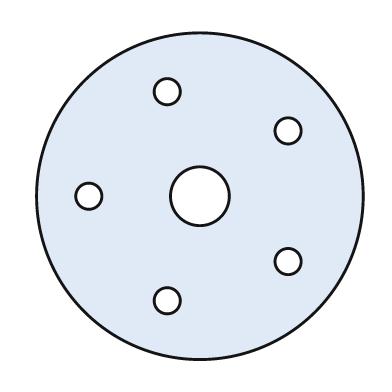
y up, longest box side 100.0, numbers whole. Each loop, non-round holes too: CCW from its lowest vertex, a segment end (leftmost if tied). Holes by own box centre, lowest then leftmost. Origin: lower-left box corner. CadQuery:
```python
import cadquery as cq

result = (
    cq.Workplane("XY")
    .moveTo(50.0, 50.0)
    .circle(50.0)
    .moveTo(40.0, 18.0)
    .circle(4.0)
    .moveTo(77.0, 30.0)
    .circle(4.0)
    .moveTo(16.0, 50.0)
    .circle(4.0)
    .moveTo(50.0, 50.0)
    .circle(9.0)
    .moveTo(77.0, 70.0)
    .circle(4.0)
    .moveTo(40.0, 82.0)
    .circle(4.0)
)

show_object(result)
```